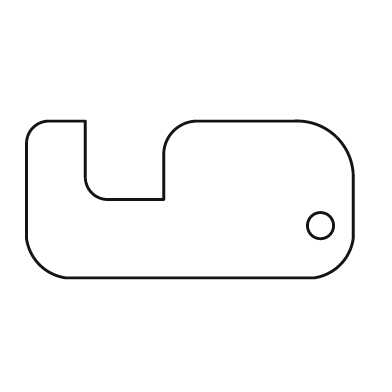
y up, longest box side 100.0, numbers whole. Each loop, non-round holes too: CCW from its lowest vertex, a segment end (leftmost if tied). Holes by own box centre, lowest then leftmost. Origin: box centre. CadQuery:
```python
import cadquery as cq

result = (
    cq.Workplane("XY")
    .moveTo(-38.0, -24.0)
    .lineTo(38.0, -24.0)
    .threePointArc((46.0, -20.0), (50.0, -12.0))
    .lineTo(50.0, 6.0)
    .threePointArc((45.0, 19.0), (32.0, 24.0))
    .lineTo(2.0, 24.0)
    .threePointArc((-5.0, 21.0), (-8.0, 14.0))
    .lineTo(-8.0, 0.0)
    .lineTo(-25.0, 0.0)
    .threePointArc((-30.0, 2.0), (-32.0, 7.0))
    .lineTo(-32.0, 24.0)
    .lineTo(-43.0, 24.0)
    .threePointArc((-48.0, 22.0), (-50.0, 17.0))
    .lineTo(-50.0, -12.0)
    .threePointArc((-46.0, -20.0), (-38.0, -24.0))
    .close()
    .moveTo(40.0, -8.0)
    .circle(4.0)
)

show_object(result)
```